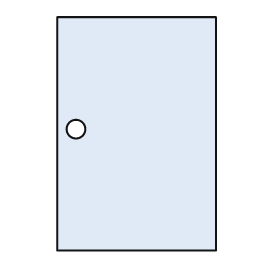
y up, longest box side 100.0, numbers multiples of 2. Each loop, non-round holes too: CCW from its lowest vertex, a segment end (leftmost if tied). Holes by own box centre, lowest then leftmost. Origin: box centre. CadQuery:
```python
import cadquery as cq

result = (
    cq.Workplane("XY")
    .moveTo(-34.0, -50.0)
    .lineTo(34.0, -50.0)
    .lineTo(34.0, 50.0)
    .lineTo(-34.0, 50.0)
    .close()
    .moveTo(-26.0, 2.0)
    .circle(4.0)
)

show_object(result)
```